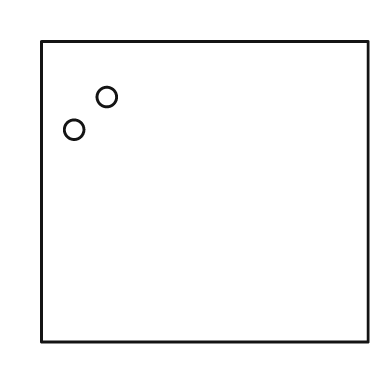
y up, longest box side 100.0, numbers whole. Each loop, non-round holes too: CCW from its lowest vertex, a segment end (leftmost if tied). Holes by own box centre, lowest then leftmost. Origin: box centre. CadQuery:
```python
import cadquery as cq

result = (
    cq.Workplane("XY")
    .moveTo(-50.0, -46.0)
    .lineTo(50.0, -46.0)
    .lineTo(50.0, 46.0)
    .lineTo(-50.0, 46.0)
    .close()
    .moveTo(-40.0, 19.0)
    .circle(3.0)
    .moveTo(-30.0, 29.0)
    .circle(3.0)
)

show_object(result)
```